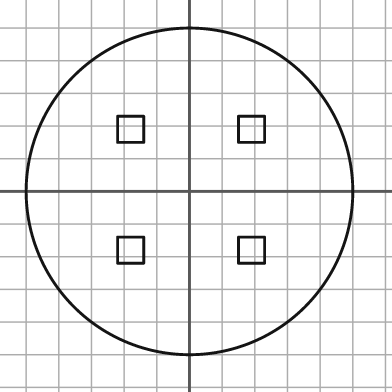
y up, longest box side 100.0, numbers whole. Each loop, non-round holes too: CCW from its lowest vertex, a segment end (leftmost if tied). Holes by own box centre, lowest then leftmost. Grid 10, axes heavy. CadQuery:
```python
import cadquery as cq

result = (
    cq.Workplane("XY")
    .moveTo(0.0, 0.0)
    .circle(50.0)
    .moveTo(-22.0, -22.0)
    .lineTo(-14.0, -22.0)
    .lineTo(-14.0, -14.0)
    .lineTo(-22.0, -14.0)
    .close()
    .moveTo(15.0, -22.0)
    .lineTo(23.0, -22.0)
    .lineTo(23.0, -14.0)
    .lineTo(15.0, -14.0)
    .close()
    .moveTo(-22.0, 15.0)
    .lineTo(-14.0, 15.0)
    .lineTo(-14.0, 23.0)
    .lineTo(-22.0, 23.0)
    .close()
    .moveTo(15.0, 15.0)
    .lineTo(23.0, 15.0)
    .lineTo(23.0, 23.0)
    .lineTo(15.0, 23.0)
    .close()
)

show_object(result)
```